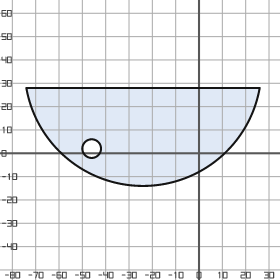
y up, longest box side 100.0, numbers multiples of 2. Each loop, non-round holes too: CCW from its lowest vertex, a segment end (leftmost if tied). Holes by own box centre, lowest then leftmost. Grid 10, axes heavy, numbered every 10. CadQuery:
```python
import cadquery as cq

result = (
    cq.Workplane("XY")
    .moveTo(-74.0, 28.0)
    .threePointArc((-24.0, -14.0), (26.0, 28.0))
    .close()
    .moveTo(-46.0, 2.0)
    .circle(4.0)
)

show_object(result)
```